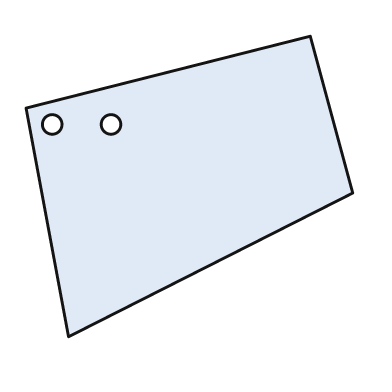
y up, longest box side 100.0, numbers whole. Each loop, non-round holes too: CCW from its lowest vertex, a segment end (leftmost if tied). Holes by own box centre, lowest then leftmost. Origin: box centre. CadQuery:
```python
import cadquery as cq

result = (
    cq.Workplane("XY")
    .moveTo(-37.0, -46.0)
    .lineTo(50.0, -2.0)
    .lineTo(37.0, 46.0)
    .lineTo(-50.0, 24.0)
    .close()
    .moveTo(-42.0, 19.0)
    .circle(3.0)
    .moveTo(-24.0, 19.0)
    .circle(3.0)
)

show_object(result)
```